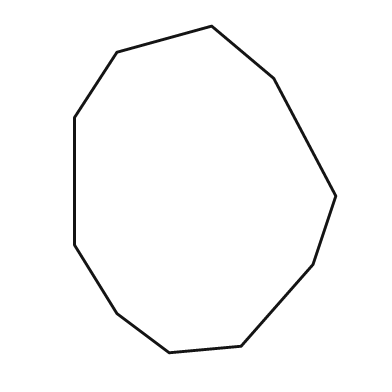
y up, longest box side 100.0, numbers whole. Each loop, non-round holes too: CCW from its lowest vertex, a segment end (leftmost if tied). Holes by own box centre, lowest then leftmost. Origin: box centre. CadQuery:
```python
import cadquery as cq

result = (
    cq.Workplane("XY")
    .moveTo(-11.0, -50.0)
    .lineTo(11.0, -48.0)
    .lineTo(33.0, -23.0)
    .lineTo(40.0, -2.0)
    .lineTo(21.0, 34.0)
    .lineTo(2.0, 50.0)
    .lineTo(-27.0, 42.0)
    .lineTo(-40.0, 22.0)
    .lineTo(-40.0, -17.0)
    .lineTo(-27.0, -38.0)
    .close()
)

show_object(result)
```